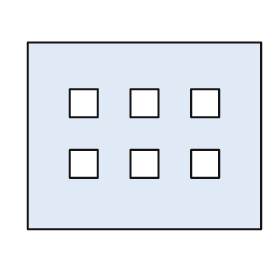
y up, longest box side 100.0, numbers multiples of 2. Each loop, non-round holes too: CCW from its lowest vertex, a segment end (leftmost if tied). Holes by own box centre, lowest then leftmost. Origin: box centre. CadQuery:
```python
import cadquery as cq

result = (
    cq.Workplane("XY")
    .moveTo(-50.0, -40.0)
    .lineTo(50.0, -40.0)
    .lineTo(50.0, 40.0)
    .lineTo(-50.0, 40.0)
    .close()
    .moveTo(-32.0, -18.0)
    .lineTo(-20.0, -18.0)
    .lineTo(-20.0, -6.0)
    .lineTo(-32.0, -6.0)
    .close()
    .moveTo(-6.0, -18.0)
    .lineTo(6.0, -18.0)
    .lineTo(6.0, -6.0)
    .lineTo(-6.0, -6.0)
    .close()
    .moveTo(20.0, -18.0)
    .lineTo(32.0, -18.0)
    .lineTo(32.0, -6.0)
    .lineTo(20.0, -6.0)
    .close()
    .moveTo(-32.0, 8.0)
    .lineTo(-20.0, 8.0)
    .lineTo(-20.0, 20.0)
    .lineTo(-32.0, 20.0)
    .close()
    .moveTo(-6.0, 8.0)
    .lineTo(6.0, 8.0)
    .lineTo(6.0, 20.0)
    .lineTo(-6.0, 20.0)
    .close()
    .moveTo(20.0, 8.0)
    .lineTo(32.0, 8.0)
    .lineTo(32.0, 20.0)
    .lineTo(20.0, 20.0)
    .close()
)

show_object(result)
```